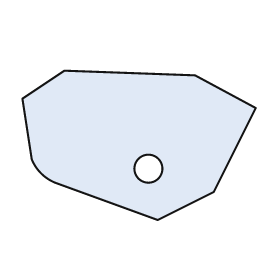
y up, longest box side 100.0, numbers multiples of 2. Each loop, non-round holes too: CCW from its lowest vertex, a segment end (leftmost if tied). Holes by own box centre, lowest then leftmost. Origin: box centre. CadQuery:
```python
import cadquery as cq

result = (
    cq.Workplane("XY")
    .moveTo(8.0, -32.0)
    .lineTo(32.0, -20.0)
    .lineTo(50.0, 16.0)
    .lineTo(24.0, 30.0)
    .lineTo(-32.0, 32.0)
    .lineTo(-50.0, 20.0)
    .lineTo(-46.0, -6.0)
    .threePointArc((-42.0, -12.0), (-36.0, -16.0))
    .close()
    .moveTo(4.0, -10.0)
    .circle(6.0)
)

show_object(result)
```